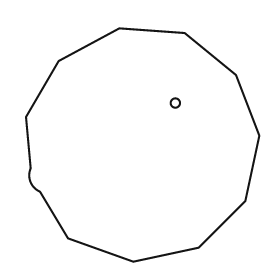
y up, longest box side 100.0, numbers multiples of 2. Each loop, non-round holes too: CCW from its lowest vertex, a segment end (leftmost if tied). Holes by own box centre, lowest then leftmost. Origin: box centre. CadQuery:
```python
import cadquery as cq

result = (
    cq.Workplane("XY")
    .moveTo(-4.0, -50.0)
    .lineTo(24.0, -44.0)
    .lineTo(44.0, -24.0)
    .lineTo(50.0, 4.0)
    .lineTo(40.0, 30.0)
    .lineTo(18.0, 48.0)
    .lineTo(-10.0, 50.0)
    .lineTo(-36.0, 36.0)
    .lineTo(-50.0, 12.0)
    .lineTo(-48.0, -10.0)
    .threePointArc((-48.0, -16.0), (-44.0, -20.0))
    .lineTo(-32.0, -40.0)
    .close()
    .moveTo(14.0, 18.0)
    .circle(2.0)
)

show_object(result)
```